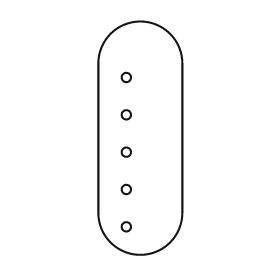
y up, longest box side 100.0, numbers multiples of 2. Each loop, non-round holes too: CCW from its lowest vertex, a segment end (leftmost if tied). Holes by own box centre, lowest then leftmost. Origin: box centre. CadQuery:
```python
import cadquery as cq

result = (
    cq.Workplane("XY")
    .moveTo(-18.0, -32.0)
    .threePointArc((0.0, -50.0), (18.0, -32.0))
    .lineTo(18.0, 32.0)
    .threePointArc((0.0, 50.0), (-18.0, 32.0))
    .close()
    .moveTo(-6.0, -38.0)
    .circle(2.0)
    .moveTo(-6.0, -22.0)
    .circle(2.0)
    .moveTo(-6.0, -6.0)
    .circle(2.0)
    .moveTo(-6.0, 10.0)
    .circle(2.0)
    .moveTo(-6.0, 26.0)
    .circle(2.0)
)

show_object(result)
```